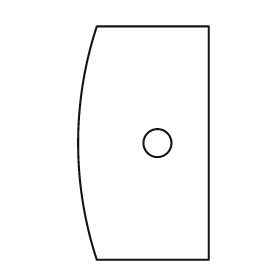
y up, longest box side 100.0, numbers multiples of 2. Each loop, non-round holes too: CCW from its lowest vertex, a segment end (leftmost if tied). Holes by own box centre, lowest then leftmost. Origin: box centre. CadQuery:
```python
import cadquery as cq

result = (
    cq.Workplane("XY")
    .moveTo(-20.0, -50.0)
    .lineTo(28.0, -50.0)
    .lineTo(28.0, 50.0)
    .lineTo(-20.0, 50.0)
    .threePointArc((-28.0, 0.0), (-20.0, -50.0))
    .close()
    .moveTo(6.0, 0.0)
    .circle(6.0)
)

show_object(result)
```